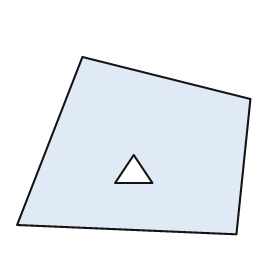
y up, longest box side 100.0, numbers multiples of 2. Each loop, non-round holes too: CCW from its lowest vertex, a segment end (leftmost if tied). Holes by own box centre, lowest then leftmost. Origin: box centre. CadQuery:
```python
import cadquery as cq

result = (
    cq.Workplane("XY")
    .moveTo(44.0, -38.0)
    .lineTo(50.0, 20.0)
    .lineTo(-22.0, 38.0)
    .lineTo(-50.0, -34.0)
    .close()
    .moveTo(-8.0, -16.0)
    .lineTo(8.0, -16.0)
    .lineTo(0.0, -4.0)
    .close()
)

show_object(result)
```